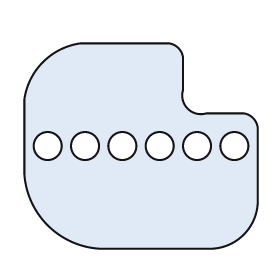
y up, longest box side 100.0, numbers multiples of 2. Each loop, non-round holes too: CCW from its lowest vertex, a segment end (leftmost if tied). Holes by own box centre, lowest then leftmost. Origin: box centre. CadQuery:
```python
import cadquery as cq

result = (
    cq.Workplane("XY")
    .moveTo(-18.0, -44.0)
    .lineTo(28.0, -44.0)
    .threePointArc((44.0, -38.0), (50.0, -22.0))
    .lineTo(50.0, 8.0)
    .threePointArc((48.0, 12.0), (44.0, 14.0))
    .lineTo(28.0, 14.0)
    .threePointArc((20.0, 16.0), (18.0, 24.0))
    .lineTo(18.0, 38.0)
    .threePointArc((16.0, 42.0), (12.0, 44.0))
    .lineTo(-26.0, 44.0)
    .threePointArc((-42.0, 36.0), (-50.0, 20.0))
    .lineTo(-50.0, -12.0)
    .threePointArc((-40.0, -34.0), (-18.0, -44.0))
    .close()
    .moveTo(-40.0, 0.0)
    .circle(6.0)
    .moveTo(-24.0, 0.0)
    .circle(6.0)
    .moveTo(-8.0, 0.0)
    .circle(6.0)
    .moveTo(8.0, 0.0)
    .circle(6.0)
    .moveTo(24.0, 0.0)
    .circle(6.0)
    .moveTo(40.0, 0.0)
    .circle(6.0)
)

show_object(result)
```